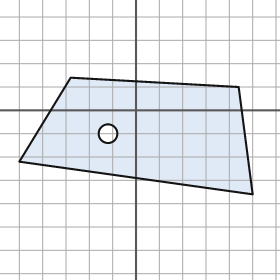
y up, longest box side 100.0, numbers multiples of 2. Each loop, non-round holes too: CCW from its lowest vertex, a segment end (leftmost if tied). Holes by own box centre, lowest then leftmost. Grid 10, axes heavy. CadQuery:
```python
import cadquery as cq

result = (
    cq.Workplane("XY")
    .moveTo(50.0, -36.0)
    .lineTo(44.0, 10.0)
    .lineTo(-28.0, 14.0)
    .lineTo(-50.0, -22.0)
    .close()
    .moveTo(-12.0, -10.0)
    .circle(4.0)
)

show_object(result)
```